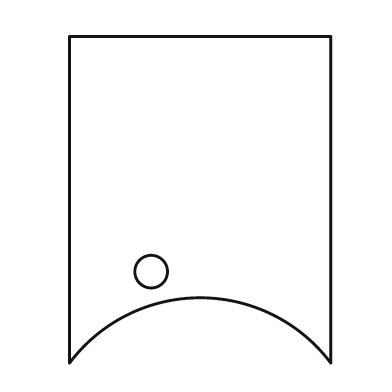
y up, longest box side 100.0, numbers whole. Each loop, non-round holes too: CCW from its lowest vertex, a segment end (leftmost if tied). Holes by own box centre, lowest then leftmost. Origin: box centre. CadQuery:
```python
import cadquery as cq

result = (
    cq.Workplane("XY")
    .moveTo(-40.0, -50.0)
    .threePointArc((0.0, -30.0), (40.0, -50.0))
    .lineTo(40.0, 50.0)
    .lineTo(-40.0, 50.0)
    .close()
    .moveTo(-15.0, -22.0)
    .circle(5.0)
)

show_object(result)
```